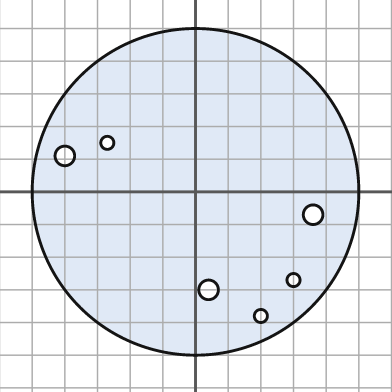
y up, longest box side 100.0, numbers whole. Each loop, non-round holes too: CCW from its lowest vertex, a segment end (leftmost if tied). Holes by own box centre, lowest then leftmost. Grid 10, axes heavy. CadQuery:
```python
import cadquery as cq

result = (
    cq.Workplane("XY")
    .moveTo(0.0, 0.0)
    .circle(50.0)
    .moveTo(20.0, -38.0)
    .circle(2.0)
    .moveTo(4.0, -30.0)
    .circle(3.0)
    .moveTo(30.0, -27.0)
    .circle(2.0)
    .moveTo(36.0, -7.0)
    .circle(3.0)
    .moveTo(-40.0, 11.0)
    .circle(3.0)
    .moveTo(-27.0, 15.0)
    .circle(2.0)
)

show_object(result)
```